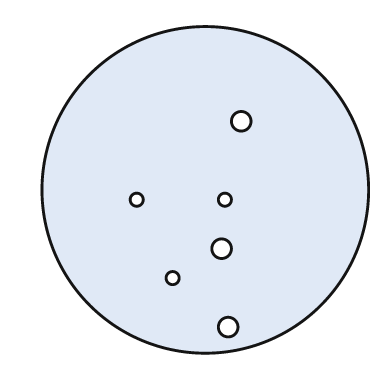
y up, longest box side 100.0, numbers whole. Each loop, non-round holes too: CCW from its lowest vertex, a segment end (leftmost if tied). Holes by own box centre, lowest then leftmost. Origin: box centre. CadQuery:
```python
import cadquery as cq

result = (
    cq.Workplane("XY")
    .moveTo(0.0, 0.0)
    .circle(50.0)
    .moveTo(7.0, -42.0)
    .circle(3.0)
    .moveTo(-10.0, -27.0)
    .circle(2.0)
    .moveTo(5.0, -18.0)
    .circle(3.0)
    .moveTo(-21.0, -3.0)
    .circle(2.0)
    .moveTo(6.0, -3.0)
    .circle(2.0)
    .moveTo(11.0, 21.0)
    .circle(3.0)
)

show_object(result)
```